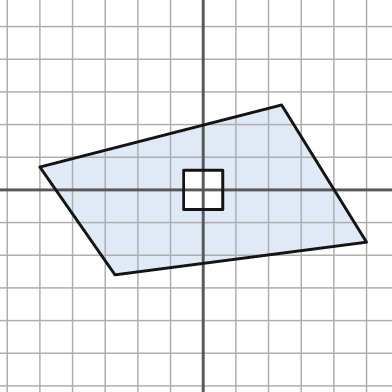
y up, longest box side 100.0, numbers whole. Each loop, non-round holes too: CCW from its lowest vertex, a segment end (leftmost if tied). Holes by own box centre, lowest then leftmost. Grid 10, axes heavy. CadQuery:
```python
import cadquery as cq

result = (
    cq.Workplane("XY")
    .moveTo(-27.0, -26.0)
    .lineTo(50.0, -16.0)
    .lineTo(24.0, 26.0)
    .lineTo(-50.0, 7.0)
    .close()
    .moveTo(-6.0, -6.0)
    .lineTo(6.0, -6.0)
    .lineTo(6.0, 6.0)
    .lineTo(-6.0, 6.0)
    .close()
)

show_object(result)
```